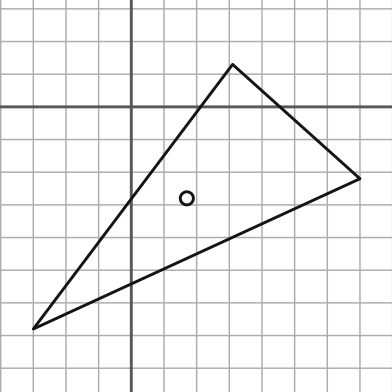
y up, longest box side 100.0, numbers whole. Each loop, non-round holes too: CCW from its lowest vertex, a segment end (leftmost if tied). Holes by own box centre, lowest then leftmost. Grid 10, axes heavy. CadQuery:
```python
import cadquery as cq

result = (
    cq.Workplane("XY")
    .moveTo(-30.0, -68.0)
    .lineTo(70.0, -22.0)
    .lineTo(31.0, 13.0)
    .close()
    .moveTo(17.0, -28.0)
    .circle(2.0)
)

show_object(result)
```